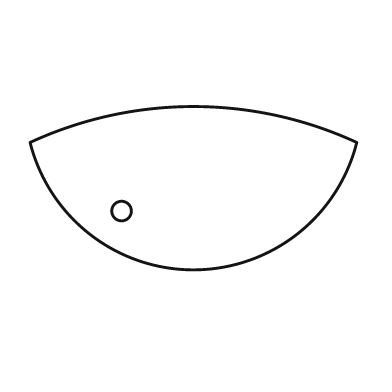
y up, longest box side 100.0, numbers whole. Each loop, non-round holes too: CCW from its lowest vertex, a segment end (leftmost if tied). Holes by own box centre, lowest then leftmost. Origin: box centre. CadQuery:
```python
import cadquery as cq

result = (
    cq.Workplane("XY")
    .moveTo(-50.0, 14.0)
    .threePointArc((0.0, -25.0), (50.0, 14.0))
    .threePointArc((0.0, 25.0), (-50.0, 14.0))
    .close()
    .moveTo(-22.0, -7.0)
    .circle(3.0)
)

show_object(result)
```